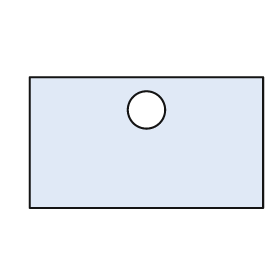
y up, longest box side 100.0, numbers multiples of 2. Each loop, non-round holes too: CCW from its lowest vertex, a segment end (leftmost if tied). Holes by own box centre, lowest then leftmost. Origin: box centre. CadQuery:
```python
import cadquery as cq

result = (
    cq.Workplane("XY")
    .moveTo(-50.0, -28.0)
    .lineTo(50.0, -28.0)
    .lineTo(50.0, 28.0)
    .lineTo(-50.0, 28.0)
    .close()
    .moveTo(0.0, 14.0)
    .circle(8.0)
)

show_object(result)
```